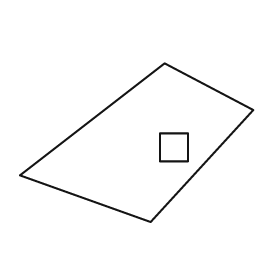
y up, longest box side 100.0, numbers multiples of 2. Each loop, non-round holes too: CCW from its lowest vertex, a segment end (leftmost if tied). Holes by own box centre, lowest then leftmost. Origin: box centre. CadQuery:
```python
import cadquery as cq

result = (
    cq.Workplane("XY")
    .moveTo(6.0, -34.0)
    .lineTo(50.0, 14.0)
    .lineTo(12.0, 34.0)
    .lineTo(-50.0, -14.0)
    .close()
    .moveTo(10.0, -8.0)
    .lineTo(22.0, -8.0)
    .lineTo(22.0, 4.0)
    .lineTo(10.0, 4.0)
    .close()
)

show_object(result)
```